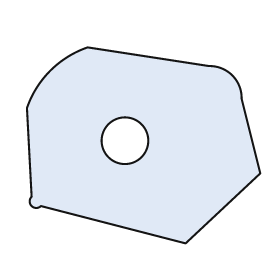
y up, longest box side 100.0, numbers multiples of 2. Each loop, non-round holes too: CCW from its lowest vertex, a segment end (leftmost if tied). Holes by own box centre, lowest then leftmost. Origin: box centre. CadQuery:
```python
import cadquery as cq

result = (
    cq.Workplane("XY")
    .moveTo(18.0, -42.0)
    .lineTo(50.0, -12.0)
    .lineTo(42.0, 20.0)
    .threePointArc((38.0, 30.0), (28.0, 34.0))
    .lineTo(-24.0, 42.0)
    .threePointArc((-40.0, 32.0), (-50.0, 16.0))
    .lineTo(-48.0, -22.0)
    .threePointArc((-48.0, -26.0), (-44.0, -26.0))
    .close()
    .moveTo(-8.0, 2.0)
    .circle(10.0)
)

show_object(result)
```